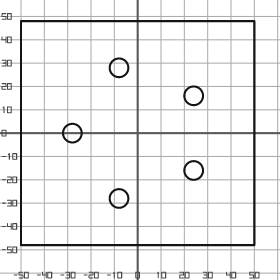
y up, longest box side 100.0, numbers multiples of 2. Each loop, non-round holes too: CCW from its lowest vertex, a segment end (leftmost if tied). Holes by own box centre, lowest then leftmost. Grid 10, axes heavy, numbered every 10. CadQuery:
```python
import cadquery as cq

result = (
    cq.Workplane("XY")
    .moveTo(-50.0, -48.0)
    .lineTo(50.0, -48.0)
    .lineTo(50.0, 48.0)
    .lineTo(-50.0, 48.0)
    .close()
    .moveTo(-8.0, -28.0)
    .circle(4.0)
    .moveTo(24.0, -16.0)
    .circle(4.0)
    .moveTo(-28.0, 0.0)
    .circle(4.0)
    .moveTo(24.0, 16.0)
    .circle(4.0)
    .moveTo(-8.0, 28.0)
    .circle(4.0)
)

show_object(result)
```